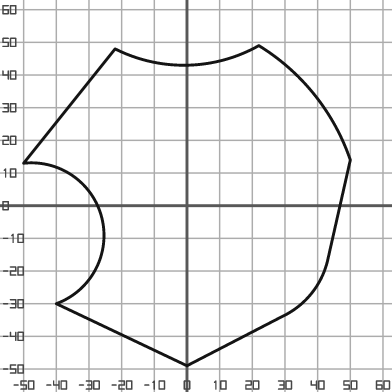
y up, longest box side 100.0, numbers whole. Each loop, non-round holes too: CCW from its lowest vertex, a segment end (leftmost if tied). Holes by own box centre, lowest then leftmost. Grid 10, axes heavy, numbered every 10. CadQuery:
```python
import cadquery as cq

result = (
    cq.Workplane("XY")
    .moveTo(0.0, -49.0)
    .lineTo(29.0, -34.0)
    .threePointArc((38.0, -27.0), (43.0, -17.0))
    .lineTo(50.0, 14.0)
    .threePointArc((39.0, 34.0), (22.0, 49.0))
    .threePointArc((0.0, 43.0), (-22.0, 48.0))
    .lineTo(-50.0, 13.0)
    .threePointArc((-26.0, -4.0), (-40.0, -30.0))
    .close()
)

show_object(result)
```